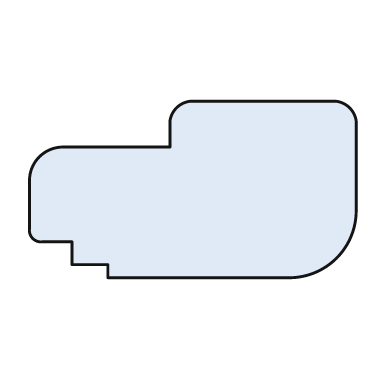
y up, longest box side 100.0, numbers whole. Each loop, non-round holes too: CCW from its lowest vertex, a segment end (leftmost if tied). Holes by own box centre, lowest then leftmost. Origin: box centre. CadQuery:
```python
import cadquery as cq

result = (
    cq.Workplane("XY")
    .moveTo(-26.0, -27.0)
    .lineTo(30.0, -27.0)
    .threePointArc((44.0, -21.0), (50.0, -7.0))
    .lineTo(50.0, 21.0)
    .threePointArc((48.0, 25.0), (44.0, 27.0))
    .lineTo(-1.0, 27.0)
    .threePointArc((-5.0, 25.0), (-7.0, 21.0))
    .lineTo(-7.0, 13.0)
    .lineTo(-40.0, 13.0)
    .threePointArc((-47.0, 10.0), (-50.0, 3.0))
    .lineTo(-50.0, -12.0)
    .threePointArc((-49.0, -15.0), (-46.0, -16.0))
    .lineTo(-37.0, -16.0)
    .lineTo(-37.0, -23.0)
    .lineTo(-26.0, -23.0)
    .close()
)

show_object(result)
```